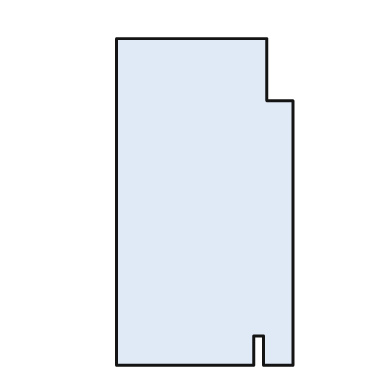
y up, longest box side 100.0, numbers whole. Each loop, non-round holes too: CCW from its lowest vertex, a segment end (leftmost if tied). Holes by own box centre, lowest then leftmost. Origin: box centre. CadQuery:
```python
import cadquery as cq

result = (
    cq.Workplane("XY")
    .moveTo(-27.0, -50.0)
    .lineTo(15.0, -50.0)
    .lineTo(15.0, -41.0)
    .lineTo(18.0, -41.0)
    .lineTo(18.0, -50.0)
    .lineTo(27.0, -50.0)
    .lineTo(27.0, 31.0)
    .lineTo(19.0, 31.0)
    .lineTo(19.0, 50.0)
    .lineTo(-27.0, 50.0)
    .close()
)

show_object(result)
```